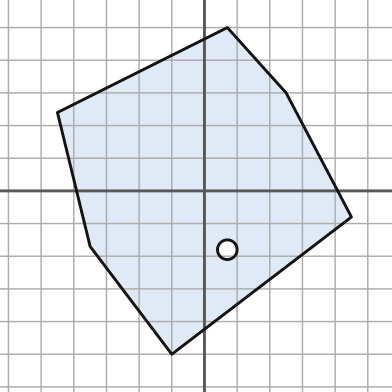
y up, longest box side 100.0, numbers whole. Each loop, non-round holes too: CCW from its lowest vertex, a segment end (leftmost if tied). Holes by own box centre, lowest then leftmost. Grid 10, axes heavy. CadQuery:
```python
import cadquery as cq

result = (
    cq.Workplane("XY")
    .moveTo(-10.0, -50.0)
    .lineTo(45.0, -8.0)
    .lineTo(25.0, 30.0)
    .lineTo(7.0, 50.0)
    .lineTo(-45.0, 24.0)
    .lineTo(-35.0, -17.0)
    .close()
    .moveTo(7.0, -18.0)
    .circle(3.0)
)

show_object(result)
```